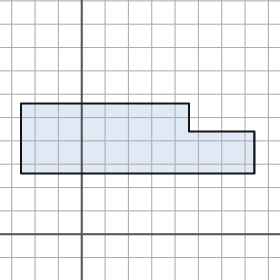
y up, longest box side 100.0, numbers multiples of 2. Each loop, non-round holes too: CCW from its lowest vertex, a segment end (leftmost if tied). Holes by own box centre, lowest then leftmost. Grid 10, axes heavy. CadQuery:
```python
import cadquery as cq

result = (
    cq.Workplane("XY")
    .moveTo(-26.0, 26.0)
    .lineTo(74.0, 26.0)
    .lineTo(74.0, 44.0)
    .lineTo(46.0, 44.0)
    .lineTo(46.0, 56.0)
    .lineTo(-26.0, 56.0)
    .close()
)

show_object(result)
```